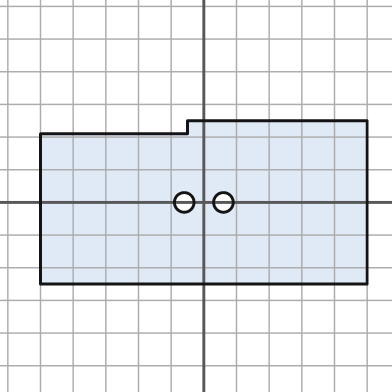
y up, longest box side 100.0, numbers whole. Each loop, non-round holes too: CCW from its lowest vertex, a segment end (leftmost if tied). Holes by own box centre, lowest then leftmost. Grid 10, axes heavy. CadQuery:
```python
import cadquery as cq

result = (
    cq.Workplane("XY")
    .moveTo(-50.0, -25.0)
    .lineTo(50.0, -25.0)
    .lineTo(50.0, 25.0)
    .lineTo(-5.0, 25.0)
    .lineTo(-5.0, 21.0)
    .lineTo(-50.0, 21.0)
    .close()
    .moveTo(-6.0, 0.0)
    .circle(3.0)
    .moveTo(6.0, 0.0)
    .circle(3.0)
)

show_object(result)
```